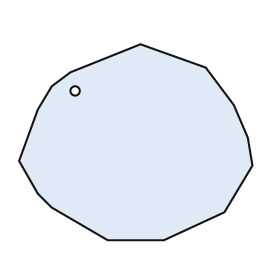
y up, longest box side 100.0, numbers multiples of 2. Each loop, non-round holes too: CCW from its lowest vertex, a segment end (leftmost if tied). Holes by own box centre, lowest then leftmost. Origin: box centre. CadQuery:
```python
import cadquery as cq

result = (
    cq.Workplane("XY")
    .moveTo(-12.0, -42.0)
    .lineTo(12.0, -42.0)
    .lineTo(38.0, -30.0)
    .lineTo(50.0, -10.0)
    .lineTo(48.0, 2.0)
    .lineTo(42.0, 16.0)
    .lineTo(30.0, 32.0)
    .lineTo(2.0, 42.0)
    .lineTo(-28.0, 30.0)
    .lineTo(-36.0, 24.0)
    .lineTo(-42.0, 14.0)
    .lineTo(-50.0, -8.0)
    .lineTo(-42.0, -22.0)
    .lineTo(-36.0, -28.0)
    .close()
    .moveTo(-26.0, 22.0)
    .circle(2.0)
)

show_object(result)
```